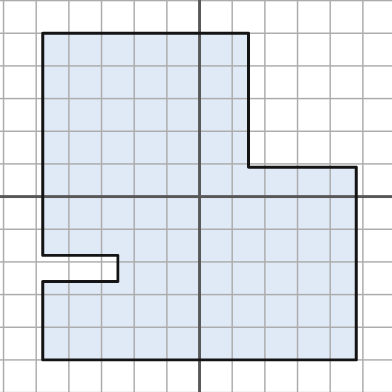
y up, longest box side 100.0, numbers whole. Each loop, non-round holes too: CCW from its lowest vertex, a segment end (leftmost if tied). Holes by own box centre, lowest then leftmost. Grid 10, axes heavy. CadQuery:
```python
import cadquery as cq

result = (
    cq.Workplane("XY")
    .moveTo(-48.0, -50.0)
    .lineTo(48.0, -50.0)
    .lineTo(48.0, 9.0)
    .lineTo(15.0, 9.0)
    .lineTo(15.0, 50.0)
    .lineTo(-48.0, 50.0)
    .lineTo(-48.0, -18.0)
    .lineTo(-25.0, -18.0)
    .lineTo(-25.0, -26.0)
    .lineTo(-48.0, -26.0)
    .close()
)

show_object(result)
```